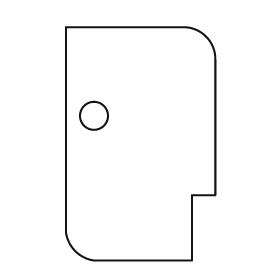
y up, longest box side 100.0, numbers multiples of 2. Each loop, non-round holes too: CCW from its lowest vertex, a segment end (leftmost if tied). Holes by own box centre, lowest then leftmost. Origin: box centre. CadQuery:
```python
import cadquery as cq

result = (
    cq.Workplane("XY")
    .moveTo(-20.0, -50.0)
    .lineTo(22.0, -50.0)
    .lineTo(22.0, -22.0)
    .lineTo(32.0, -22.0)
    .lineTo(32.0, 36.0)
    .threePointArc((28.0, 46.0), (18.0, 50.0))
    .lineTo(-32.0, 50.0)
    .lineTo(-32.0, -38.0)
    .threePointArc((-28.0, -46.0), (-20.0, -50.0))
    .close()
    .moveTo(-20.0, 12.0)
    .circle(6.0)
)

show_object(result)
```